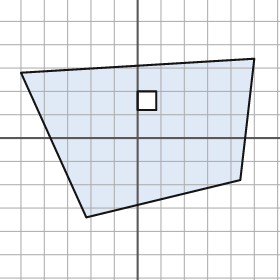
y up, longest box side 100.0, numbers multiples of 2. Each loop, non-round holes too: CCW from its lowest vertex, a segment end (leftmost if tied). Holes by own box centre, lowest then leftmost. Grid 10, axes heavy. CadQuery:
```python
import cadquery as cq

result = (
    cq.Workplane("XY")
    .moveTo(-22.0, -34.0)
    .lineTo(44.0, -18.0)
    .lineTo(50.0, 34.0)
    .lineTo(-50.0, 28.0)
    .close()
    .moveTo(0.0, 12.0)
    .lineTo(8.0, 12.0)
    .lineTo(8.0, 20.0)
    .lineTo(0.0, 20.0)
    .close()
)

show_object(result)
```